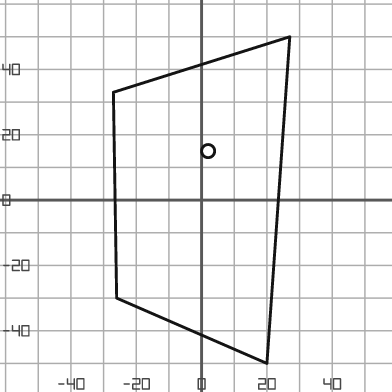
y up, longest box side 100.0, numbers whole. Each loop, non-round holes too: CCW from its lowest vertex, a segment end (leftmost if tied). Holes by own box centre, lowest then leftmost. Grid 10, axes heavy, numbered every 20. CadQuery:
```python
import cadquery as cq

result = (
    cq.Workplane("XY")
    .moveTo(20.0, -50.0)
    .lineTo(27.0, 50.0)
    .lineTo(-27.0, 33.0)
    .lineTo(-26.0, -30.0)
    .close()
    .moveTo(2.0, 15.0)
    .circle(2.0)
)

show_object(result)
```